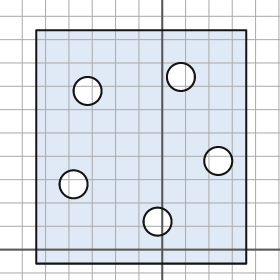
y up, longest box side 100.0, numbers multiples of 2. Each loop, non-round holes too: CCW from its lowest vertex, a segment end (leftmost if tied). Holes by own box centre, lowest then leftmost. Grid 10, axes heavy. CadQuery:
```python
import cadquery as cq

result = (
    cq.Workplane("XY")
    .moveTo(-54.0, -6.0)
    .lineTo(36.0, -6.0)
    .lineTo(36.0, 94.0)
    .lineTo(-54.0, 94.0)
    .close()
    .moveTo(-2.0, 12.0)
    .circle(6.0)
    .moveTo(-38.0, 28.0)
    .circle(6.0)
    .moveTo(24.0, 38.0)
    .circle(6.0)
    .moveTo(-32.0, 68.0)
    .circle(6.0)
    .moveTo(8.0, 74.0)
    .circle(6.0)
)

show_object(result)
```